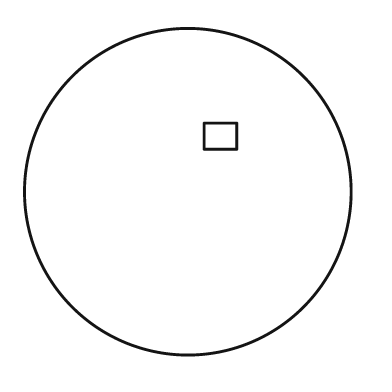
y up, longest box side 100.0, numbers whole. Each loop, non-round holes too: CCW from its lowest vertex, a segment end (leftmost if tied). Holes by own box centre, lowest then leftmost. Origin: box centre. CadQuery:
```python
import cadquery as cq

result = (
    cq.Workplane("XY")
    .moveTo(0.0, 0.0)
    .circle(50.0)
    .moveTo(5.0, 13.0)
    .lineTo(15.0, 13.0)
    .lineTo(15.0, 21.0)
    .lineTo(5.0, 21.0)
    .close()
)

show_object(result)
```